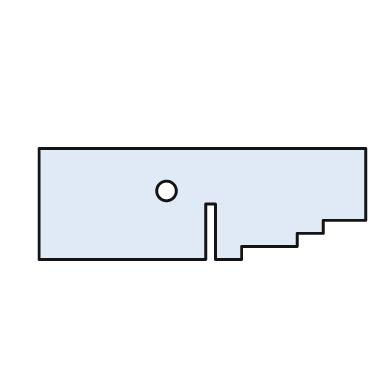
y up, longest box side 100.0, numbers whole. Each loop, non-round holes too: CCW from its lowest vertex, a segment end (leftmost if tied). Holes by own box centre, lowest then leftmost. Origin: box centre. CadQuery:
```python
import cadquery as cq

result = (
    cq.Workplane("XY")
    .moveTo(-50.0, -17.0)
    .lineTo(1.0, -17.0)
    .lineTo(1.0, 0.0)
    .lineTo(4.0, 0.0)
    .lineTo(4.0, -17.0)
    .lineTo(12.0, -17.0)
    .lineTo(12.0, -13.0)
    .lineTo(29.0, -13.0)
    .lineTo(29.0, -9.0)
    .lineTo(37.0, -9.0)
    .lineTo(37.0, -5.0)
    .lineTo(50.0, -5.0)
    .lineTo(50.0, 17.0)
    .lineTo(-50.0, 17.0)
    .close()
    .moveTo(-11.0, 4.0)
    .circle(3.0)
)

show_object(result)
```